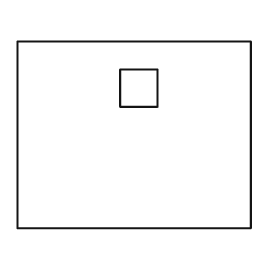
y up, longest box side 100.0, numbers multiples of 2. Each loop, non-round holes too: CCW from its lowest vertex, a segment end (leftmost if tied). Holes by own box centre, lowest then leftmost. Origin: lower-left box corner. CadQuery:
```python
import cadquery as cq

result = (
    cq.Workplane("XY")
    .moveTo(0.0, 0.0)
    .lineTo(100.0, 0.0)
    .lineTo(100.0, 80.0)
    .lineTo(0.0, 80.0)
    .close()
    .moveTo(44.0, 52.0)
    .lineTo(60.0, 52.0)
    .lineTo(60.0, 68.0)
    .lineTo(44.0, 68.0)
    .close()
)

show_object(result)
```